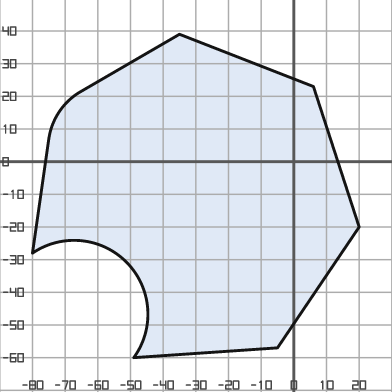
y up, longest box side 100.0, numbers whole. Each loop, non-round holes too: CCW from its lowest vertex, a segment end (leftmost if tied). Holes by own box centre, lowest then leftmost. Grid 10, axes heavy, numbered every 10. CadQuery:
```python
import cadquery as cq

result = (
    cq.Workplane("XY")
    .moveTo(-49.0, -60.0)
    .lineTo(-5.0, -57.0)
    .lineTo(20.0, -20.0)
    .lineTo(6.0, 23.0)
    .lineTo(-35.0, 39.0)
    .lineTo(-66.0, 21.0)
    .threePointArc((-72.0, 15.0), (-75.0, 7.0))
    .lineTo(-80.0, -28.0)
    .threePointArc((-51.0, -31.0), (-49.0, -60.0))
    .close()
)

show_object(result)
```